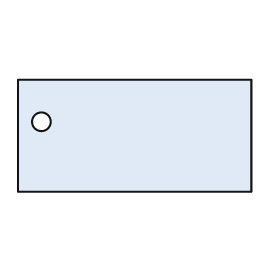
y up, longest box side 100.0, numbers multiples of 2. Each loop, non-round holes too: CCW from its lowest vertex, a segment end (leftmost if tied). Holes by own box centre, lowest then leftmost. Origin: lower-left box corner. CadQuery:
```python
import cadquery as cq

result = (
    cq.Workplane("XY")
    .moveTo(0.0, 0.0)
    .lineTo(100.0, 0.0)
    .lineTo(100.0, 48.0)
    .lineTo(0.0, 48.0)
    .close()
    .moveTo(10.0, 30.0)
    .circle(4.0)
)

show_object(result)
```